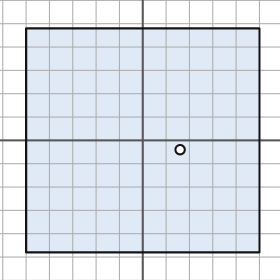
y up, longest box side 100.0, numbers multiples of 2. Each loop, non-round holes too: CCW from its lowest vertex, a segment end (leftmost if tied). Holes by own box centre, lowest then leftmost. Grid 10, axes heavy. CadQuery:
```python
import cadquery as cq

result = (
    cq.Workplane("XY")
    .moveTo(-50.0, -48.0)
    .lineTo(50.0, -48.0)
    .lineTo(50.0, 48.0)
    .lineTo(-50.0, 48.0)
    .close()
    .moveTo(16.0, -4.0)
    .circle(2.0)
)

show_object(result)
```